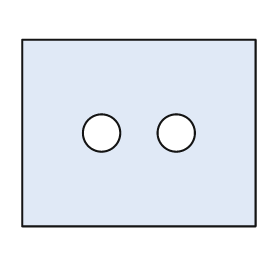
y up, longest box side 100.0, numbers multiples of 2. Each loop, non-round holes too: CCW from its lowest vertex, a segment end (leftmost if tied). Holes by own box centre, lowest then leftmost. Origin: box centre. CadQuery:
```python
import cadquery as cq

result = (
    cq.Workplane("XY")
    .moveTo(-50.0, -40.0)
    .lineTo(50.0, -40.0)
    .lineTo(50.0, 40.0)
    .lineTo(-50.0, 40.0)
    .close()
    .moveTo(-16.0, 0.0)
    .circle(8.0)
    .moveTo(16.0, 0.0)
    .circle(8.0)
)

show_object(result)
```